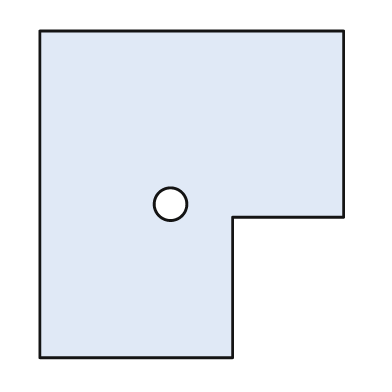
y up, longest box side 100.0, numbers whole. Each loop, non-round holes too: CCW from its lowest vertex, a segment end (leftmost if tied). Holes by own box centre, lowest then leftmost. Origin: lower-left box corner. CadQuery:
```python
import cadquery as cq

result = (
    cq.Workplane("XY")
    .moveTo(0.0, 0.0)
    .lineTo(59.0, 0.0)
    .lineTo(59.0, 43.0)
    .lineTo(93.0, 43.0)
    .lineTo(93.0, 100.0)
    .lineTo(0.0, 100.0)
    .close()
    .moveTo(40.0, 47.0)
    .circle(5.0)
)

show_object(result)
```